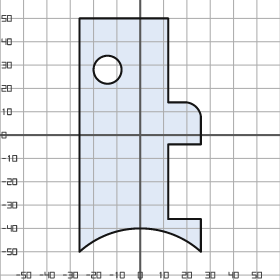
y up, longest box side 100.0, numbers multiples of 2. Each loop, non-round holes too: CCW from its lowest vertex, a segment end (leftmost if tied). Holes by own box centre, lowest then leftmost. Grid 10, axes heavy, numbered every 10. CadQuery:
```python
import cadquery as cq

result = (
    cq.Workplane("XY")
    .moveTo(-26.0, -50.0)
    .threePointArc((0.0, -40.0), (26.0, -50.0))
    .lineTo(26.0, -36.0)
    .lineTo(12.0, -36.0)
    .lineTo(12.0, -4.0)
    .lineTo(26.0, -4.0)
    .lineTo(26.0, 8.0)
    .threePointArc((24.0, 12.0), (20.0, 14.0))
    .lineTo(12.0, 14.0)
    .lineTo(12.0, 50.0)
    .lineTo(-26.0, 50.0)
    .close()
    .moveTo(-14.0, 28.0)
    .circle(6.0)
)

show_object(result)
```